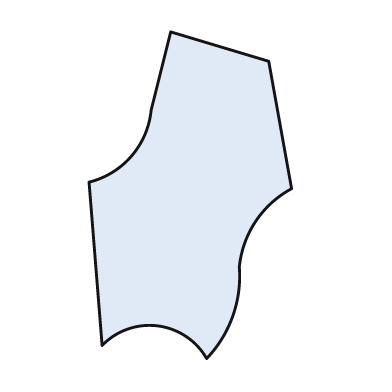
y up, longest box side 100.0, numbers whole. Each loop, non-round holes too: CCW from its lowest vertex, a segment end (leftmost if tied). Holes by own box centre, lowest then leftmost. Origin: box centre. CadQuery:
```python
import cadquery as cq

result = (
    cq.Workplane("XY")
    .moveTo(5.0, -50.0)
    .threePointArc((13.0, -37.0), (15.0, -22.0))
    .threePointArc((20.0, -8.0), (31.0, 2.0))
    .lineTo(24.0, 41.0)
    .lineTo(-6.0, 50.0)
    .lineTo(-12.0, 26.0)
    .threePointArc((-18.0, 12.0), (-31.0, 4.0))
    .lineTo(-27.0, -46.0)
    .threePointArc((-10.0, -40.0), (5.0, -50.0))
    .close()
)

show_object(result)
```